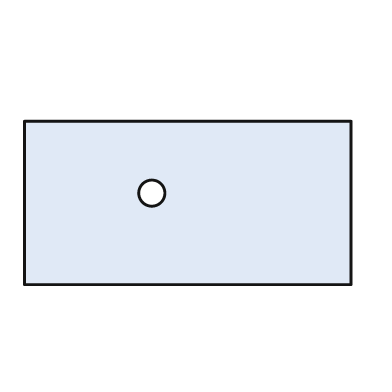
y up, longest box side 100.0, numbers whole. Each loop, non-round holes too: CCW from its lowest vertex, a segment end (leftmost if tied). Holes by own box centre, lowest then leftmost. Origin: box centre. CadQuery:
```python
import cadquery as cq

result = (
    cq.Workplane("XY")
    .moveTo(-50.0, -25.0)
    .lineTo(50.0, -25.0)
    .lineTo(50.0, 25.0)
    .lineTo(-50.0, 25.0)
    .close()
    .moveTo(-11.0, 3.0)
    .circle(4.0)
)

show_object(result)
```